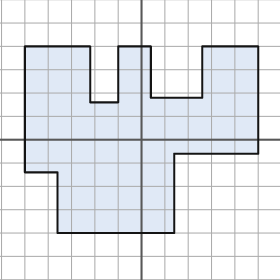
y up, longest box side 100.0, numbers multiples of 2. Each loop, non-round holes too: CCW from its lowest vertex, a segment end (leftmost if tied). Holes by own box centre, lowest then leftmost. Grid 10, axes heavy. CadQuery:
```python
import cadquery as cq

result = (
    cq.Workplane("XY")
    .moveTo(-36.0, -40.0)
    .lineTo(14.0, -40.0)
    .lineTo(14.0, -6.0)
    .lineTo(50.0, -6.0)
    .lineTo(50.0, 40.0)
    .lineTo(26.0, 40.0)
    .lineTo(26.0, 18.0)
    .lineTo(4.0, 18.0)
    .lineTo(4.0, 40.0)
    .lineTo(-10.0, 40.0)
    .lineTo(-10.0, 16.0)
    .lineTo(-22.0, 16.0)
    .lineTo(-22.0, 40.0)
    .lineTo(-50.0, 40.0)
    .lineTo(-50.0, -14.0)
    .lineTo(-36.0, -14.0)
    .close()
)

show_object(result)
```